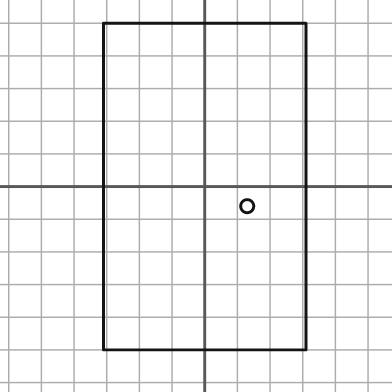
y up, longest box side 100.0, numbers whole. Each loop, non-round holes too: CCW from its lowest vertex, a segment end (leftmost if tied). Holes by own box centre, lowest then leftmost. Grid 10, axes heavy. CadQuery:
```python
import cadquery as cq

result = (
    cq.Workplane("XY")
    .moveTo(-31.0, -50.0)
    .lineTo(31.0, -50.0)
    .lineTo(31.0, 50.0)
    .lineTo(-31.0, 50.0)
    .close()
    .moveTo(13.0, -6.0)
    .circle(2.0)
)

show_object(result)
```